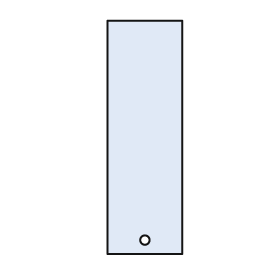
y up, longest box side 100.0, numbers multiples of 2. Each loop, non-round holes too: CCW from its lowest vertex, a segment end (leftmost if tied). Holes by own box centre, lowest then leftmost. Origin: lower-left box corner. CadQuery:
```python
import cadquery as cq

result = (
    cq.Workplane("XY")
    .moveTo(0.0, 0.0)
    .lineTo(32.0, 0.0)
    .lineTo(32.0, 100.0)
    .lineTo(0.0, 100.0)
    .close()
    .moveTo(16.0, 6.0)
    .circle(2.0)
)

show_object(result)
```